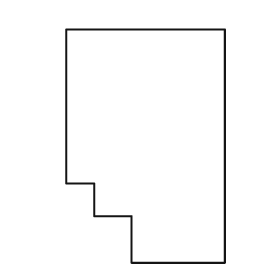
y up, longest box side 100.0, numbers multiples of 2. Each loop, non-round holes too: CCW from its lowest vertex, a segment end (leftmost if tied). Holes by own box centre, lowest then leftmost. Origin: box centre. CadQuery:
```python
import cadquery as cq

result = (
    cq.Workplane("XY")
    .moveTo(-6.0, -50.0)
    .lineTo(34.0, -50.0)
    .lineTo(34.0, 50.0)
    .lineTo(-34.0, 50.0)
    .lineTo(-34.0, -16.0)
    .lineTo(-22.0, -16.0)
    .lineTo(-22.0, -30.0)
    .lineTo(-6.0, -30.0)
    .close()
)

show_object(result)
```